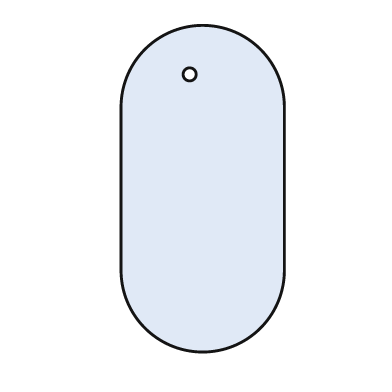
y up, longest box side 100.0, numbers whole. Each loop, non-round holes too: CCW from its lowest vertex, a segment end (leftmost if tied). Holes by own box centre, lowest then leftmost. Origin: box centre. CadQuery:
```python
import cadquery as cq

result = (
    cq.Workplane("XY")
    .moveTo(-25.0, -25.0)
    .threePointArc((0.0, -50.0), (25.0, -25.0))
    .lineTo(25.0, 25.0)
    .threePointArc((0.0, 50.0), (-25.0, 25.0))
    .close()
    .moveTo(-4.0, 35.0)
    .circle(2.0)
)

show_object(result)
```